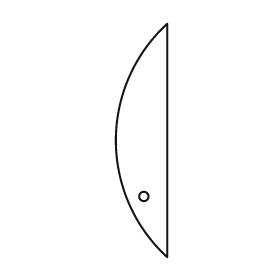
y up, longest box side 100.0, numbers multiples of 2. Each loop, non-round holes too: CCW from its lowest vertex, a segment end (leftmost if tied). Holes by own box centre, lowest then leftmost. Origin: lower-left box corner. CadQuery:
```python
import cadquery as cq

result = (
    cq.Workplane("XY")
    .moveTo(22.0, 0.0)
    .lineTo(22.0, 100.0)
    .threePointArc((0.0, 50.0), (22.0, 0.0))
    .close()
    .moveTo(12.0, 26.0)
    .circle(2.0)
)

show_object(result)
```